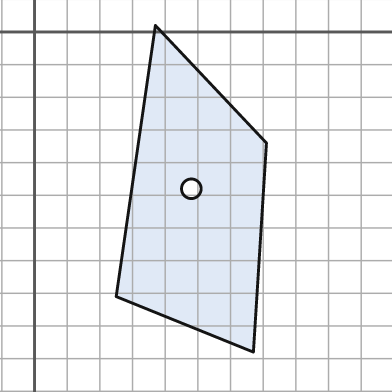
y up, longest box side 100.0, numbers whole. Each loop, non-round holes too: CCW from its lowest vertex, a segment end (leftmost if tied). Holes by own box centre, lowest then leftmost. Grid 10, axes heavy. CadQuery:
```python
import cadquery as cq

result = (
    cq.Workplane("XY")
    .moveTo(67.0, -98.0)
    .lineTo(71.0, -34.0)
    .lineTo(37.0, 2.0)
    .lineTo(25.0, -81.0)
    .close()
    .moveTo(48.0, -48.0)
    .circle(3.0)
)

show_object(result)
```